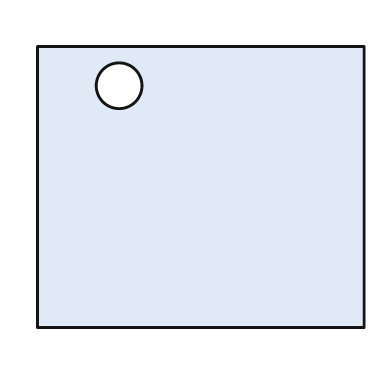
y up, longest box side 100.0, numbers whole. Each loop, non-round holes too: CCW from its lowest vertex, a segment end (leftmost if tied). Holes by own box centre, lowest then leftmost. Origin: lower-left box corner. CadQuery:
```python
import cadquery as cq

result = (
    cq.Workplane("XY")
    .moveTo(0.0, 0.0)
    .lineTo(100.0, 0.0)
    .lineTo(100.0, 86.0)
    .lineTo(0.0, 86.0)
    .close()
    .moveTo(25.0, 74.0)
    .circle(7.0)
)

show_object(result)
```